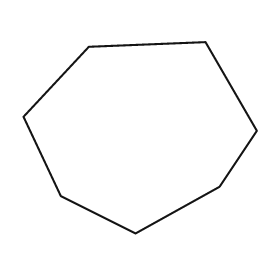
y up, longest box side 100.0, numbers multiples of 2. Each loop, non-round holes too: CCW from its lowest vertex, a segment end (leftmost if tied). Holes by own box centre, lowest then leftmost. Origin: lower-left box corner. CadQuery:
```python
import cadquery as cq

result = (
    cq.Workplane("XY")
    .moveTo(48.0, 0.0)
    .lineTo(84.0, 20.0)
    .lineTo(100.0, 44.0)
    .lineTo(78.0, 82.0)
    .lineTo(28.0, 80.0)
    .lineTo(0.0, 50.0)
    .lineTo(16.0, 16.0)
    .close()
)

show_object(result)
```